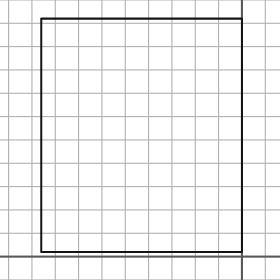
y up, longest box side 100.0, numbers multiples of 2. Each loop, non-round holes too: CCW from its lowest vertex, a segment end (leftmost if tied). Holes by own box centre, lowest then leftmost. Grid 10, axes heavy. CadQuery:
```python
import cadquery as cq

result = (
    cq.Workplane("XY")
    .moveTo(-86.0, 2.0)
    .lineTo(0.0, 2.0)
    .lineTo(0.0, 102.0)
    .lineTo(-86.0, 102.0)
    .close()
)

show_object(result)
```